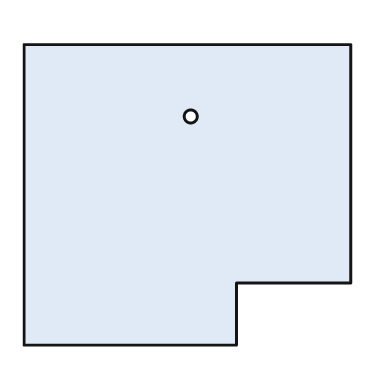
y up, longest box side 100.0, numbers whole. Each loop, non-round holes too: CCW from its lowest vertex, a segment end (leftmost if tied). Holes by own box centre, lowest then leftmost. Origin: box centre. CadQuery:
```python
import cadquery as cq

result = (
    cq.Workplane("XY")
    .moveTo(-50.0, -46.0)
    .lineTo(15.0, -46.0)
    .lineTo(15.0, -27.0)
    .lineTo(50.0, -27.0)
    .lineTo(50.0, 46.0)
    .lineTo(-50.0, 46.0)
    .close()
    .moveTo(1.0, 24.0)
    .circle(2.0)
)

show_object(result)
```